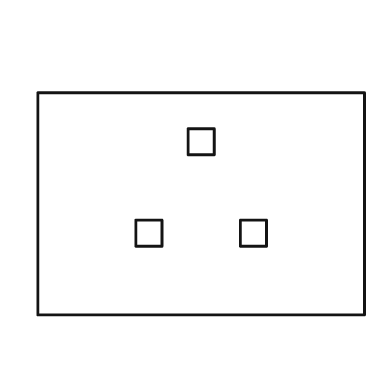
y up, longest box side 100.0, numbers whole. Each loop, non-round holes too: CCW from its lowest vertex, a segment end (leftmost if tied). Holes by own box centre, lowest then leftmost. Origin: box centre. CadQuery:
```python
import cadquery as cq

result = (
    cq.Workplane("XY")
    .moveTo(-50.0, -34.0)
    .lineTo(50.0, -34.0)
    .lineTo(50.0, 34.0)
    .lineTo(-50.0, 34.0)
    .close()
    .moveTo(-20.0, -13.0)
    .lineTo(-12.0, -13.0)
    .lineTo(-12.0, -5.0)
    .lineTo(-20.0, -5.0)
    .close()
    .moveTo(12.0, -13.0)
    .lineTo(20.0, -13.0)
    .lineTo(20.0, -5.0)
    .lineTo(12.0, -5.0)
    .close()
    .moveTo(-4.0, 15.0)
    .lineTo(4.0, 15.0)
    .lineTo(4.0, 23.0)
    .lineTo(-4.0, 23.0)
    .close()
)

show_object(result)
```